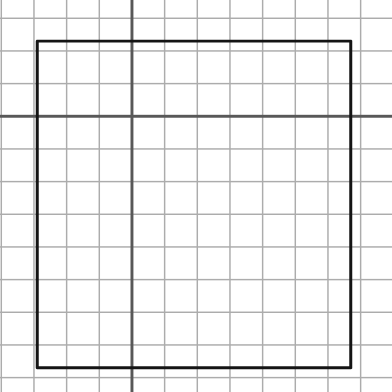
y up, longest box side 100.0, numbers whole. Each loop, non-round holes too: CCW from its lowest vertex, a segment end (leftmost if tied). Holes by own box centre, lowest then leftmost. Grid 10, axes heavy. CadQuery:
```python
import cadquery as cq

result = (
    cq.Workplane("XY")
    .moveTo(-29.0, -77.0)
    .lineTo(67.0, -77.0)
    .lineTo(67.0, 23.0)
    .lineTo(-29.0, 23.0)
    .close()
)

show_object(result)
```